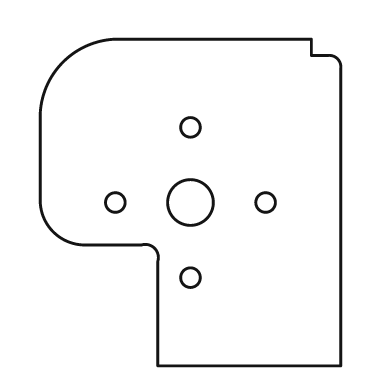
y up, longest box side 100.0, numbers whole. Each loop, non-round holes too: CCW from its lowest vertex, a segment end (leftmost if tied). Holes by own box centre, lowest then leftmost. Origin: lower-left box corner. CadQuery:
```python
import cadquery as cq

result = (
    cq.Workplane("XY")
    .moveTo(36.0, 0.0)
    .lineTo(92.0, 0.0)
    .lineTo(92.0, 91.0)
    .threePointArc((91.0, 94.0), (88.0, 95.0))
    .lineTo(83.0, 95.0)
    .lineTo(83.0, 100.0)
    .lineTo(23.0, 100.0)
    .threePointArc((7.0, 93.0), (0.0, 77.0))
    .lineTo(0.0, 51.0)
    .threePointArc((4.0, 41.0), (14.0, 37.0))
    .lineTo(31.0, 37.0)
    .threePointArc((35.0, 36.0), (36.0, 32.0))
    .close()
    .moveTo(46.0, 27.0)
    .circle(3.0)
    .moveTo(23.0, 50.0)
    .circle(3.0)
    .moveTo(46.0, 50.0)
    .circle(7.0)
    .moveTo(69.0, 50.0)
    .circle(3.0)
    .moveTo(46.0, 73.0)
    .circle(3.0)
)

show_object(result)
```